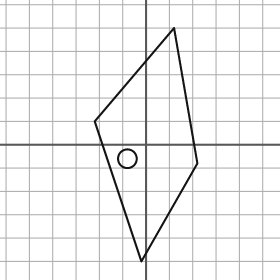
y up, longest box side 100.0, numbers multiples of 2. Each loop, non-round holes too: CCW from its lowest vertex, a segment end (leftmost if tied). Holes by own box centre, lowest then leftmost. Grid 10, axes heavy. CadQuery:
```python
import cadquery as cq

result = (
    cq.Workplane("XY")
    .moveTo(-2.0, -50.0)
    .lineTo(22.0, -8.0)
    .lineTo(12.0, 50.0)
    .lineTo(-22.0, 10.0)
    .close()
    .moveTo(-8.0, -6.0)
    .circle(4.0)
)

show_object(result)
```